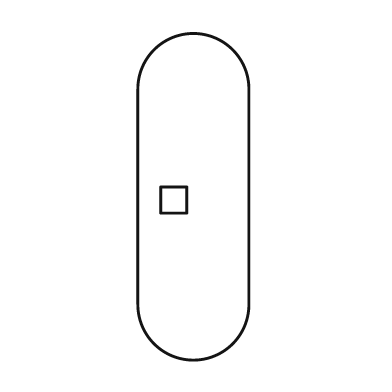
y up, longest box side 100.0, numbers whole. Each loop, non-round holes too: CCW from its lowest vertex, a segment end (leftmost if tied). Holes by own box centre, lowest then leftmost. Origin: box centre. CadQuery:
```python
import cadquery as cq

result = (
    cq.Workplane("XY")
    .moveTo(-17.0, -33.0)
    .threePointArc((0.0, -50.0), (17.0, -33.0))
    .lineTo(17.0, 33.0)
    .threePointArc((0.0, 50.0), (-17.0, 33.0))
    .close()
    .moveTo(-10.0, -5.0)
    .lineTo(-2.0, -5.0)
    .lineTo(-2.0, 3.0)
    .lineTo(-10.0, 3.0)
    .close()
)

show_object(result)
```